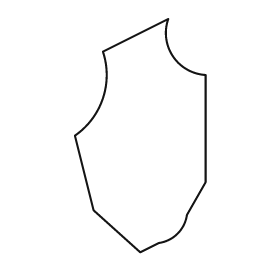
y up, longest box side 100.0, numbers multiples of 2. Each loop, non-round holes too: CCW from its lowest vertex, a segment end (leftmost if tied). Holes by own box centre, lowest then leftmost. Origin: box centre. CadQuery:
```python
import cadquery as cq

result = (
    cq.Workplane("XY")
    .moveTo(0.0, -50.0)
    .lineTo(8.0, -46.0)
    .threePointArc((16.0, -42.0), (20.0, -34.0))
    .lineTo(28.0, -20.0)
    .lineTo(28.0, 26.0)
    .threePointArc((14.0, 34.0), (12.0, 50.0))
    .lineTo(-16.0, 36.0)
    .threePointArc((-16.0, 16.0), (-28.0, 0.0))
    .lineTo(-20.0, -32.0)
    .close()
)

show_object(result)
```